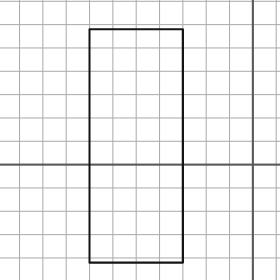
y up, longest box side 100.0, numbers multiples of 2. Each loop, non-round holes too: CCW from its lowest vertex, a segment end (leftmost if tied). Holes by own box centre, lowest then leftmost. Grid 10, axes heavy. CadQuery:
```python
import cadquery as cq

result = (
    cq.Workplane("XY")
    .moveTo(-70.0, -42.0)
    .lineTo(-30.0, -42.0)
    .lineTo(-30.0, 58.0)
    .lineTo(-70.0, 58.0)
    .close()
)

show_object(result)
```